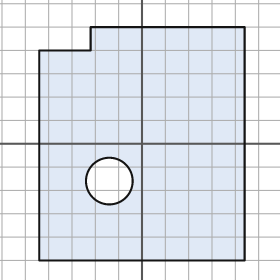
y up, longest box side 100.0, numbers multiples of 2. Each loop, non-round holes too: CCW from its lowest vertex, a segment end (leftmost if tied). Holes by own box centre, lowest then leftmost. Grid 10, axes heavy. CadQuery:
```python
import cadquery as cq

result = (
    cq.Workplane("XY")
    .moveTo(-44.0, -50.0)
    .lineTo(44.0, -50.0)
    .lineTo(44.0, 50.0)
    .lineTo(-22.0, 50.0)
    .lineTo(-22.0, 40.0)
    .lineTo(-44.0, 40.0)
    .close()
    .moveTo(-14.0, -16.0)
    .circle(10.0)
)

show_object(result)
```